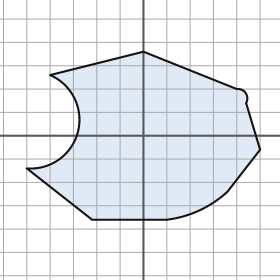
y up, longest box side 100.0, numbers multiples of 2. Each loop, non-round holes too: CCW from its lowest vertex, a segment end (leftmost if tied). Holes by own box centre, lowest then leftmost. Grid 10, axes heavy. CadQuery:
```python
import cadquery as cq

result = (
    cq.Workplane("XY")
    .moveTo(-22.0, -36.0)
    .lineTo(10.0, -36.0)
    .threePointArc((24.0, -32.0), (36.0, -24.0))
    .lineTo(50.0, -6.0)
    .lineTo(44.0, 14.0)
    .threePointArc((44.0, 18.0), (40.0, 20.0))
    .lineTo(0.0, 36.0)
    .lineTo(-40.0, 26.0)
    .threePointArc((-28.0, 2.0), (-50.0, -14.0))
    .close()
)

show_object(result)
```